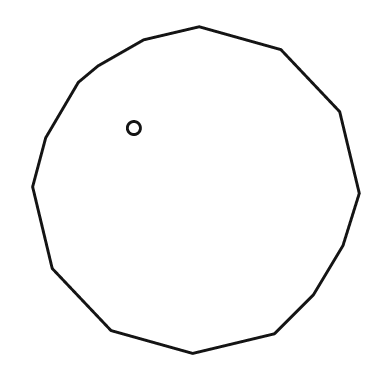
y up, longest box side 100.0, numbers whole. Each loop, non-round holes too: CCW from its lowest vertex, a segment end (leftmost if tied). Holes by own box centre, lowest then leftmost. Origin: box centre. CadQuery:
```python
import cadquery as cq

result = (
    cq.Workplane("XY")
    .moveTo(-1.0, -50.0)
    .lineTo(24.0, -44.0)
    .lineTo(36.0, -32.0)
    .lineTo(45.0, -17.0)
    .lineTo(50.0, -1.0)
    .lineTo(44.0, 24.0)
    .lineTo(26.0, 43.0)
    .lineTo(1.0, 50.0)
    .lineTo(-16.0, 46.0)
    .lineTo(-30.0, 38.0)
    .lineTo(-36.0, 33.0)
    .lineTo(-46.0, 16.0)
    .lineTo(-50.0, 1.0)
    .lineTo(-44.0, -24.0)
    .lineTo(-26.0, -43.0)
    .close()
    .moveTo(-19.0, 19.0)
    .circle(2.0)
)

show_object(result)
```